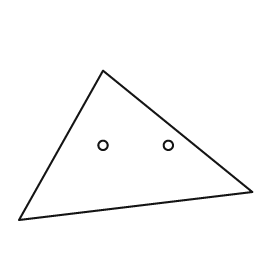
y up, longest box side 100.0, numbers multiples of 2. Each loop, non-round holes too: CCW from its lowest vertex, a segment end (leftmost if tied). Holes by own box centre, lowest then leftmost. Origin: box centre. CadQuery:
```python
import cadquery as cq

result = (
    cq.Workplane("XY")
    .moveTo(-50.0, -32.0)
    .lineTo(50.0, -20.0)
    .lineTo(-14.0, 32.0)
    .close()
    .moveTo(-14.0, 0.0)
    .circle(2.0)
    .moveTo(14.0, 0.0)
    .circle(2.0)
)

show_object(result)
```